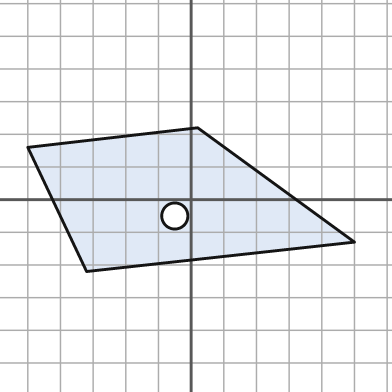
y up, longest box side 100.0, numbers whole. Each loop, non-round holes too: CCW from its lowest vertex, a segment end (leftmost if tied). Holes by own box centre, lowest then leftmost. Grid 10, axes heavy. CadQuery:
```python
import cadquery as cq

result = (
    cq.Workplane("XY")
    .moveTo(-32.0, -22.0)
    .lineTo(50.0, -13.0)
    .lineTo(2.0, 22.0)
    .lineTo(-50.0, 16.0)
    .close()
    .moveTo(-5.0, -5.0)
    .circle(4.0)
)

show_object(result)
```